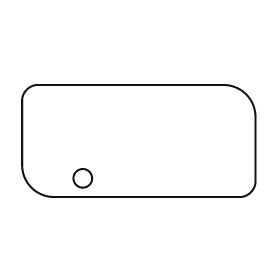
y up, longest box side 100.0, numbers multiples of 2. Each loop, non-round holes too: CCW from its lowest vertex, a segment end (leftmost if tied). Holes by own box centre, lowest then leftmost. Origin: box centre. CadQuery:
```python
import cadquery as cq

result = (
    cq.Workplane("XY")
    .moveTo(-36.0, -24.0)
    .lineTo(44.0, -24.0)
    .threePointArc((48.0, -22.0), (50.0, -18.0))
    .lineTo(50.0, 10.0)
    .threePointArc((46.0, 20.0), (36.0, 24.0))
    .lineTo(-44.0, 24.0)
    .threePointArc((-48.0, 22.0), (-50.0, 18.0))
    .lineTo(-50.0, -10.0)
    .threePointArc((-46.0, -20.0), (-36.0, -24.0))
    .close()
    .moveTo(-24.0, -16.0)
    .circle(4.0)
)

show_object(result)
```